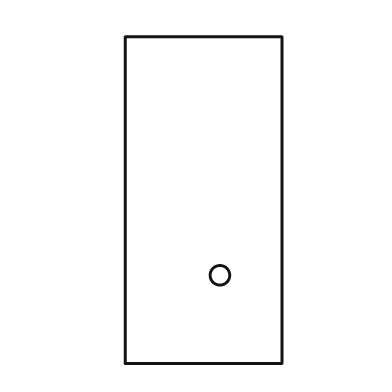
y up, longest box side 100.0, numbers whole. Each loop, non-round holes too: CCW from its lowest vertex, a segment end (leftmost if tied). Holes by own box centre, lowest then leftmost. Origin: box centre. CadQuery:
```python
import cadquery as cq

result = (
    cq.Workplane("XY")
    .moveTo(-24.0, -50.0)
    .lineTo(24.0, -50.0)
    .lineTo(24.0, 50.0)
    .lineTo(-24.0, 50.0)
    .close()
    .moveTo(5.0, -23.0)
    .circle(3.0)
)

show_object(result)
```